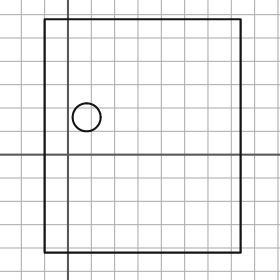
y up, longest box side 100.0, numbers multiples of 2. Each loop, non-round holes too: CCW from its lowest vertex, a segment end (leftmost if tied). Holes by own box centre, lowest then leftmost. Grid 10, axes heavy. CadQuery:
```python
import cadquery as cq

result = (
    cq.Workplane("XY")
    .moveTo(-10.0, -42.0)
    .lineTo(74.0, -42.0)
    .lineTo(74.0, 58.0)
    .lineTo(-10.0, 58.0)
    .close()
    .moveTo(8.0, 16.0)
    .circle(6.0)
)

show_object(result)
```